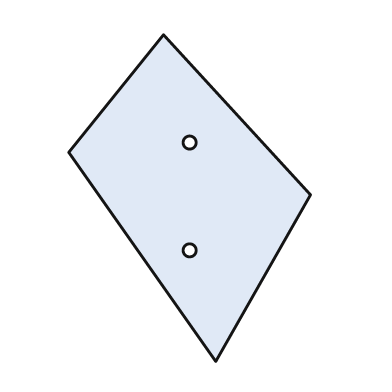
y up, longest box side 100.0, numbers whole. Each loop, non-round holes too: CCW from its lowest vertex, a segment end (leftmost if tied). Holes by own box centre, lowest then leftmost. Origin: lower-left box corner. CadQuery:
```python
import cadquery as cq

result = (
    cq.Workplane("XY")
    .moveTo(45.0, 0.0)
    .lineTo(74.0, 51.0)
    .lineTo(29.0, 100.0)
    .lineTo(0.0, 64.0)
    .close()
    .moveTo(37.0, 34.0)
    .circle(2.0)
    .moveTo(37.0, 67.0)
    .circle(2.0)
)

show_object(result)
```